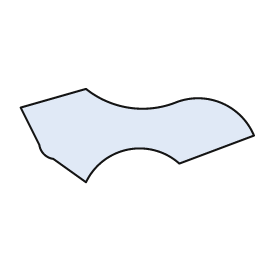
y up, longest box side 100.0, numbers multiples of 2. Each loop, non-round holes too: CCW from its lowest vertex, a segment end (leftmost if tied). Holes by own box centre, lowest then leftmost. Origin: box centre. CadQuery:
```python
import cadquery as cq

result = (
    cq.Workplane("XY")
    .moveTo(-22.0, -20.0)
    .threePointArc((-4.0, -6.0), (18.0, -12.0))
    .lineTo(50.0, 0.0)
    .threePointArc((36.0, 14.0), (16.0, 14.0))
    .threePointArc((-4.0, 12.0), (-22.0, 20.0))
    .lineTo(-50.0, 12.0)
    .lineTo(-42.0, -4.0)
    .threePointArc((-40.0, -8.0), (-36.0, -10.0))
    .close()
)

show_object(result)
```